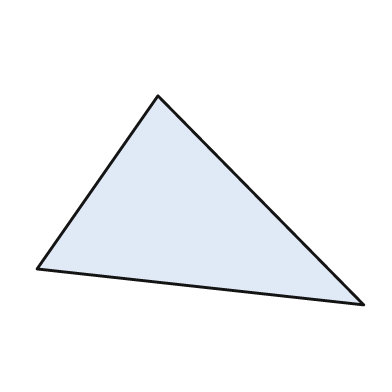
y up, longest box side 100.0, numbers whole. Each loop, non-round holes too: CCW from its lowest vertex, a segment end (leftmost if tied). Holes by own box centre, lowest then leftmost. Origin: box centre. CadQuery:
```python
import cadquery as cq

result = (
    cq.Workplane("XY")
    .moveTo(50.0, -32.0)
    .lineTo(-13.0, 32.0)
    .lineTo(-50.0, -21.0)
    .close()
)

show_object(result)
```